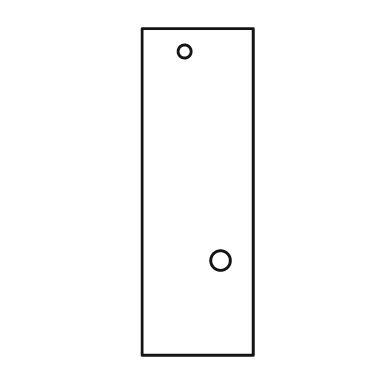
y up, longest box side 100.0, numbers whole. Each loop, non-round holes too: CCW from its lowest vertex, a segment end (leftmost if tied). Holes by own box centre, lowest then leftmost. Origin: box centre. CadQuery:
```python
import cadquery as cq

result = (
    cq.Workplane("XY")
    .moveTo(-17.0, -50.0)
    .lineTo(17.0, -50.0)
    .lineTo(17.0, 50.0)
    .lineTo(-17.0, 50.0)
    .close()
    .moveTo(7.0, -21.0)
    .circle(3.0)
    .moveTo(-4.0, 43.0)
    .circle(2.0)
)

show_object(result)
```